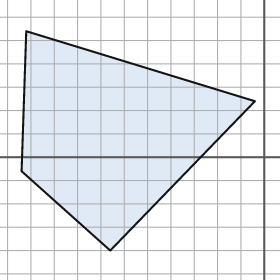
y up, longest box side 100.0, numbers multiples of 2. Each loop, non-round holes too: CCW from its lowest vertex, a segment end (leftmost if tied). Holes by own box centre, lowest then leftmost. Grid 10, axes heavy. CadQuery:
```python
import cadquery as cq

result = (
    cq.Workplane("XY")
    .moveTo(-66.0, -40.0)
    .lineTo(-4.0, 24.0)
    .lineTo(-102.0, 54.0)
    .lineTo(-104.0, -6.0)
    .close()
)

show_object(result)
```